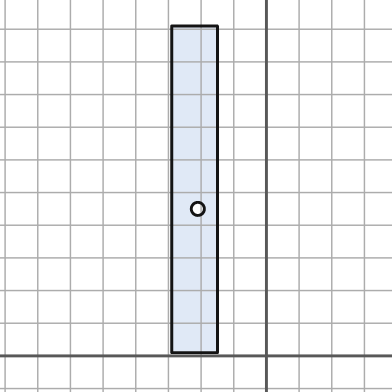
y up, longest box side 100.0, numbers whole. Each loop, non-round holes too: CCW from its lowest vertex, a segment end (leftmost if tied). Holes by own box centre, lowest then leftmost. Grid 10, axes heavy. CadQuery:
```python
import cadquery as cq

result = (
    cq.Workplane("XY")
    .moveTo(-29.0, 1.0)
    .lineTo(-15.0, 1.0)
    .lineTo(-15.0, 101.0)
    .lineTo(-29.0, 101.0)
    .close()
    .moveTo(-21.0, 45.0)
    .circle(2.0)
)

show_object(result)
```